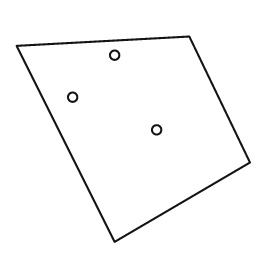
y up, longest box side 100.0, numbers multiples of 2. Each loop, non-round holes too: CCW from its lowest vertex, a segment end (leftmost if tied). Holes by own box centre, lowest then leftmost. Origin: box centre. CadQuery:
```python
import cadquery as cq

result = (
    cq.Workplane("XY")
    .moveTo(-8.0, -44.0)
    .lineTo(50.0, -10.0)
    .lineTo(24.0, 44.0)
    .lineTo(-50.0, 40.0)
    .close()
    .moveTo(10.0, 4.0)
    .circle(2.0)
    .moveTo(-26.0, 18.0)
    .circle(2.0)
    .moveTo(-8.0, 36.0)
    .circle(2.0)
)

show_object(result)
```